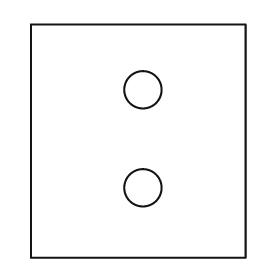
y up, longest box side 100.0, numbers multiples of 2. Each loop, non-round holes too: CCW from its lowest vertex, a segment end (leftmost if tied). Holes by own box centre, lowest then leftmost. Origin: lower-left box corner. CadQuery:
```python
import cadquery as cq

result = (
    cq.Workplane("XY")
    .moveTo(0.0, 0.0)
    .lineTo(92.0, 0.0)
    .lineTo(92.0, 100.0)
    .lineTo(0.0, 100.0)
    .close()
    .moveTo(48.0, 30.0)
    .circle(8.0)
    .moveTo(48.0, 72.0)
    .circle(8.0)
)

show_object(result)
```